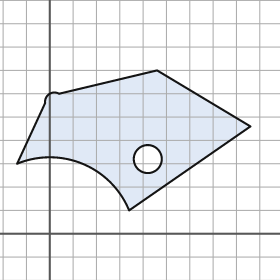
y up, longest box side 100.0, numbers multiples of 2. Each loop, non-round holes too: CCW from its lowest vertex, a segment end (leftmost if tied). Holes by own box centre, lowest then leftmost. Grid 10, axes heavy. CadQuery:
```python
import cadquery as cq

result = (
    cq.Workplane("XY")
    .moveTo(34.0, 10.0)
    .lineTo(86.0, 46.0)
    .lineTo(46.0, 70.0)
    .lineTo(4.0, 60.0)
    .threePointArc((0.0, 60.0), (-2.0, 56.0))
    .lineTo(-14.0, 30.0)
    .threePointArc((14.0, 30.0), (34.0, 10.0))
    .close()
    .moveTo(42.0, 32.0)
    .circle(6.0)
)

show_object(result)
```